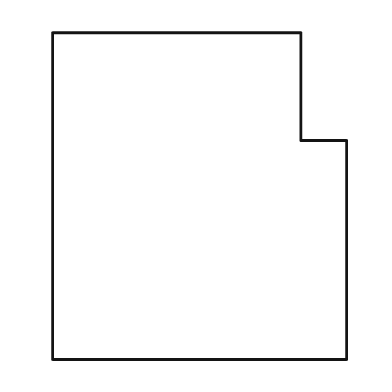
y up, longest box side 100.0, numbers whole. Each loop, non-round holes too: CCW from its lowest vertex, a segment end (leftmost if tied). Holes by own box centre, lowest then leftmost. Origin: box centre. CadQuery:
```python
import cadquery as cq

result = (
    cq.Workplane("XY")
    .moveTo(-45.0, -50.0)
    .lineTo(45.0, -50.0)
    .lineTo(45.0, 17.0)
    .lineTo(31.0, 17.0)
    .lineTo(31.0, 50.0)
    .lineTo(-45.0, 50.0)
    .close()
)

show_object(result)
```